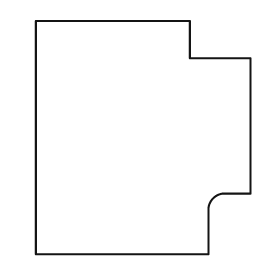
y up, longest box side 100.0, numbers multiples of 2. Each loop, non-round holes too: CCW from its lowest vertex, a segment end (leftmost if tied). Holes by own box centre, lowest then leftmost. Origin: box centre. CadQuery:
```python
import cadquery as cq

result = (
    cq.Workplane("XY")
    .moveTo(-46.0, -50.0)
    .lineTo(28.0, -50.0)
    .lineTo(28.0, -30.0)
    .threePointArc((30.0, -26.0), (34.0, -24.0))
    .lineTo(46.0, -24.0)
    .lineTo(46.0, 34.0)
    .lineTo(20.0, 34.0)
    .lineTo(20.0, 50.0)
    .lineTo(-46.0, 50.0)
    .close()
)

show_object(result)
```